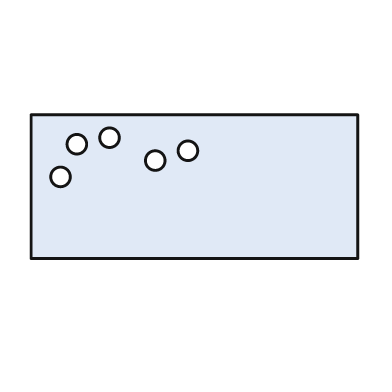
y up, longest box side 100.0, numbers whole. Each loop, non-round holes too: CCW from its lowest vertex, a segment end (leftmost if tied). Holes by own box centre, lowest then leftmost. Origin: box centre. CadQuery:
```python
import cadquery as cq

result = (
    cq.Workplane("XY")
    .moveTo(-50.0, -22.0)
    .lineTo(50.0, -22.0)
    .lineTo(50.0, 22.0)
    .lineTo(-50.0, 22.0)
    .close()
    .moveTo(-41.0, 3.0)
    .circle(3.0)
    .moveTo(-12.0, 8.0)
    .circle(3.0)
    .moveTo(-2.0, 11.0)
    .circle(3.0)
    .moveTo(-36.0, 13.0)
    .circle(3.0)
    .moveTo(-26.0, 15.0)
    .circle(3.0)
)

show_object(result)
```